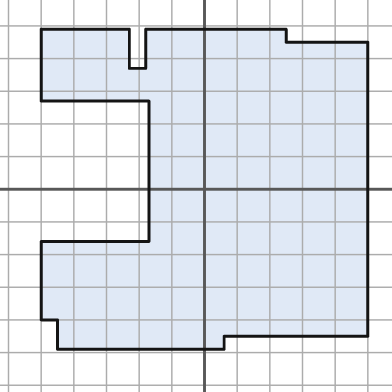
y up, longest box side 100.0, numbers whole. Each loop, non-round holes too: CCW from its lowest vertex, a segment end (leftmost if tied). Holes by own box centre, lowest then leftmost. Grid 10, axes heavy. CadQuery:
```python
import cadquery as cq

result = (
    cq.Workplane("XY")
    .moveTo(-45.0, -49.0)
    .lineTo(6.0, -49.0)
    .lineTo(6.0, -45.0)
    .lineTo(50.0, -45.0)
    .lineTo(50.0, 45.0)
    .lineTo(25.0, 45.0)
    .lineTo(25.0, 49.0)
    .lineTo(-18.0, 49.0)
    .lineTo(-18.0, 37.0)
    .lineTo(-23.0, 37.0)
    .lineTo(-23.0, 49.0)
    .lineTo(-50.0, 49.0)
    .lineTo(-50.0, 27.0)
    .lineTo(-17.0, 27.0)
    .lineTo(-17.0, -16.0)
    .lineTo(-50.0, -16.0)
    .lineTo(-50.0, -40.0)
    .lineTo(-45.0, -40.0)
    .close()
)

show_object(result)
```